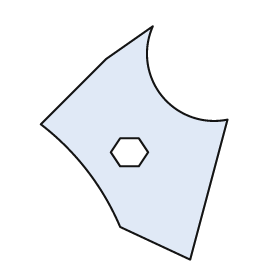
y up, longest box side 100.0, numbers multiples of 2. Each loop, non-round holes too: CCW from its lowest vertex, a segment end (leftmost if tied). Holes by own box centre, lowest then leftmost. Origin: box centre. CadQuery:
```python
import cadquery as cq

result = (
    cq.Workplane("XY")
    .moveTo(24.0, -50.0)
    .lineTo(40.0, 10.0)
    .threePointArc((12.0, 20.0), (8.0, 50.0))
    .lineTo(-12.0, 36.0)
    .lineTo(-40.0, 8.0)
    .threePointArc((-20.0, -12.0), (-6.0, -36.0))
    .close()
    .moveTo(-6.0, -10.0)
    .lineTo(2.0, -10.0)
    .lineTo(6.0, -4.0)
    .lineTo(2.0, 2.0)
    .lineTo(-6.0, 2.0)
    .lineTo(-10.0, -4.0)
    .close()
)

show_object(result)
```